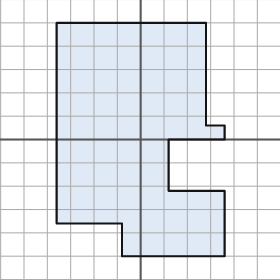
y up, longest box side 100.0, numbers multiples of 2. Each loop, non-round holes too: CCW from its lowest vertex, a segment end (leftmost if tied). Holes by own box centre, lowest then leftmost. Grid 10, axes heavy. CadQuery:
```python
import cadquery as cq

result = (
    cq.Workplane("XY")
    .moveTo(-8.0, -50.0)
    .lineTo(36.0, -50.0)
    .lineTo(36.0, -22.0)
    .lineTo(12.0, -22.0)
    .lineTo(12.0, 0.0)
    .lineTo(36.0, 0.0)
    .lineTo(36.0, 6.0)
    .lineTo(28.0, 6.0)
    .lineTo(28.0, 50.0)
    .lineTo(-36.0, 50.0)
    .lineTo(-36.0, -36.0)
    .lineTo(-8.0, -36.0)
    .close()
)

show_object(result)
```